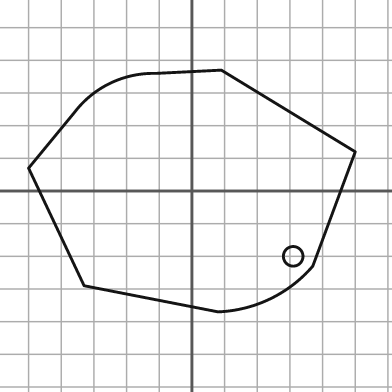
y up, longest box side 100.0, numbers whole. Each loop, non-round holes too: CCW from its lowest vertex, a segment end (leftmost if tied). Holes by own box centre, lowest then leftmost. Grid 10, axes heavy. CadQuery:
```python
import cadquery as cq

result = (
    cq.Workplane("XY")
    .moveTo(8.0, -37.0)
    .threePointArc((24.0, -33.0), (37.0, -23.0))
    .lineTo(50.0, 12.0)
    .lineTo(9.0, 37.0)
    .lineTo(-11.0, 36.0)
    .threePointArc((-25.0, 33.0), (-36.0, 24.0))
    .lineTo(-50.0, 7.0)
    .lineTo(-33.0, -29.0)
    .close()
    .moveTo(31.0, -20.0)
    .circle(3.0)
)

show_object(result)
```